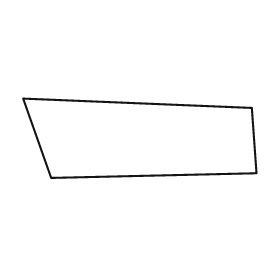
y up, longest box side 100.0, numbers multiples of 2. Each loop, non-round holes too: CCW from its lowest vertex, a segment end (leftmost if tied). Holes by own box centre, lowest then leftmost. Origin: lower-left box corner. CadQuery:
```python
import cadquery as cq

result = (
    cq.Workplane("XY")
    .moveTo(12.0, 0.0)
    .lineTo(100.0, 2.0)
    .lineTo(98.0, 30.0)
    .lineTo(0.0, 34.0)
    .close()
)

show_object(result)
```